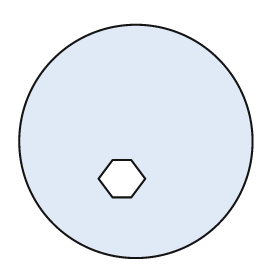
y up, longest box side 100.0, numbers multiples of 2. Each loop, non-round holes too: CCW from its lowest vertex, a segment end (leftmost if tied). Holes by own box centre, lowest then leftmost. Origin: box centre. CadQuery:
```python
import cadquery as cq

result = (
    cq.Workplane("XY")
    .moveTo(0.0, 0.0)
    .circle(50.0)
    .moveTo(-10.0, -24.0)
    .lineTo(-2.0, -24.0)
    .lineTo(4.0, -16.0)
    .lineTo(-2.0, -8.0)
    .lineTo(-10.0, -8.0)
    .lineTo(-16.0, -16.0)
    .close()
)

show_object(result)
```